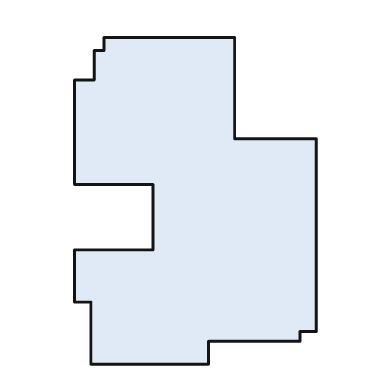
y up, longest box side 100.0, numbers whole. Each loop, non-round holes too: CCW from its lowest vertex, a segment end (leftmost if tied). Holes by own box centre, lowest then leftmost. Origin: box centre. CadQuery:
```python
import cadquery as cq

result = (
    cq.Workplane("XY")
    .moveTo(-32.0, -50.0)
    .lineTo(4.0, -50.0)
    .lineTo(4.0, -43.0)
    .lineTo(32.0, -43.0)
    .lineTo(32.0, -40.0)
    .lineTo(37.0, -40.0)
    .lineTo(37.0, 19.0)
    .lineTo(12.0, 19.0)
    .lineTo(12.0, 50.0)
    .lineTo(-28.0, 50.0)
    .lineTo(-28.0, 46.0)
    .lineTo(-31.0, 46.0)
    .lineTo(-31.0, 37.0)
    .lineTo(-37.0, 37.0)
    .lineTo(-37.0, 5.0)
    .lineTo(-13.0, 5.0)
    .lineTo(-13.0, -15.0)
    .lineTo(-37.0, -15.0)
    .lineTo(-37.0, -31.0)
    .lineTo(-32.0, -31.0)
    .close()
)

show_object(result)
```